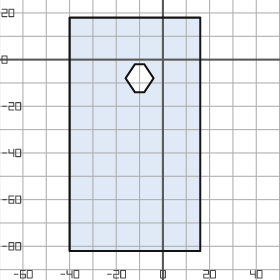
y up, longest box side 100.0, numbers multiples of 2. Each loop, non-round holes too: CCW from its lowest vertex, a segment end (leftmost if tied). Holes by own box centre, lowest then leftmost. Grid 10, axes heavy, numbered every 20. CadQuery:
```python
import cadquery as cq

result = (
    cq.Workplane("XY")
    .moveTo(-40.0, -82.0)
    .lineTo(16.0, -82.0)
    .lineTo(16.0, 18.0)
    .lineTo(-40.0, 18.0)
    .close()
    .moveTo(-12.0, -14.0)
    .lineTo(-8.0, -14.0)
    .lineTo(-4.0, -8.0)
    .lineTo(-8.0, -2.0)
    .lineTo(-12.0, -2.0)
    .lineTo(-16.0, -8.0)
    .close()
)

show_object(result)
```